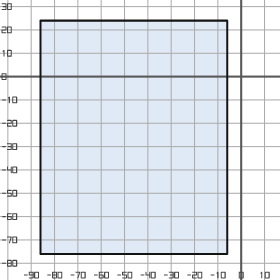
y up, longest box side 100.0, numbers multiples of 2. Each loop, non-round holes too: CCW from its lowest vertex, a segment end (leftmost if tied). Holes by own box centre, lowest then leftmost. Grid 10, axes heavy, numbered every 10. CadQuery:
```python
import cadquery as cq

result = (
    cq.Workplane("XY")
    .moveTo(-86.0, -76.0)
    .lineTo(-6.0, -76.0)
    .lineTo(-6.0, 24.0)
    .lineTo(-86.0, 24.0)
    .close()
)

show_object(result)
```